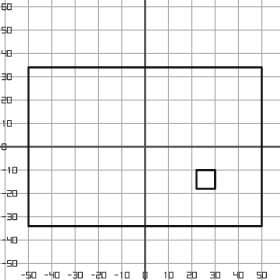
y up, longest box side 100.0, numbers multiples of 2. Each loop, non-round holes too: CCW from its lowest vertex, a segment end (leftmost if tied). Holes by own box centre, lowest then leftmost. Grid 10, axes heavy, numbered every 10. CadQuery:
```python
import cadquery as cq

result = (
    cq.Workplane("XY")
    .moveTo(-50.0, -34.0)
    .lineTo(50.0, -34.0)
    .lineTo(50.0, 34.0)
    .lineTo(-50.0, 34.0)
    .close()
    .moveTo(22.0, -18.0)
    .lineTo(30.0, -18.0)
    .lineTo(30.0, -10.0)
    .lineTo(22.0, -10.0)
    .close()
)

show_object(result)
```